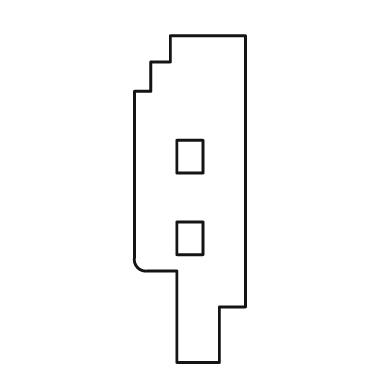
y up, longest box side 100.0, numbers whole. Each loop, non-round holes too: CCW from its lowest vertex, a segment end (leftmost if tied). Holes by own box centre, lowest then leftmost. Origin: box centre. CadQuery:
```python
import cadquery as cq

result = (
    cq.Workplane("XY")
    .moveTo(-4.0, -50.0)
    .lineTo(9.0, -50.0)
    .lineTo(9.0, -33.0)
    .lineTo(17.0, -33.0)
    .lineTo(17.0, 50.0)
    .lineTo(-6.0, 50.0)
    .lineTo(-6.0, 42.0)
    .lineTo(-12.0, 42.0)
    .lineTo(-12.0, 33.0)
    .lineTo(-17.0, 33.0)
    .lineTo(-17.0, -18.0)
    .threePointArc((-16.0, -21.0), (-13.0, -22.0))
    .lineTo(-4.0, -22.0)
    .close()
    .moveTo(-4.0, -17.0)
    .lineTo(4.0, -17.0)
    .lineTo(4.0, -7.0)
    .lineTo(-4.0, -7.0)
    .close()
    .moveTo(-4.0, 8.0)
    .lineTo(4.0, 8.0)
    .lineTo(4.0, 18.0)
    .lineTo(-4.0, 18.0)
    .close()
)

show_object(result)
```